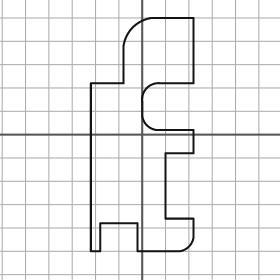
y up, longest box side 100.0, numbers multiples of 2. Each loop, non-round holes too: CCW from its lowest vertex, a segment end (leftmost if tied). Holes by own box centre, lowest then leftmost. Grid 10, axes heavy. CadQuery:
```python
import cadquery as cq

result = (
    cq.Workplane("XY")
    .moveTo(-22.0, -50.0)
    .lineTo(-18.0, -50.0)
    .lineTo(-18.0, -38.0)
    .lineTo(-2.0, -38.0)
    .lineTo(-2.0, -50.0)
    .lineTo(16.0, -50.0)
    .threePointArc((20.0, -48.0), (22.0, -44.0))
    .lineTo(22.0, -36.0)
    .lineTo(10.0, -36.0)
    .lineTo(10.0, -8.0)
    .lineTo(22.0, -8.0)
    .lineTo(22.0, 2.0)
    .lineTo(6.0, 2.0)
    .threePointArc((2.0, 4.0), (0.0, 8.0))
    .lineTo(0.0, 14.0)
    .threePointArc((2.0, 20.0), (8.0, 22.0))
    .lineTo(22.0, 22.0)
    .lineTo(22.0, 50.0)
    .lineTo(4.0, 50.0)
    .threePointArc((-4.0, 46.0), (-8.0, 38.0))
    .lineTo(-8.0, 22.0)
    .lineTo(-22.0, 22.0)
    .close()
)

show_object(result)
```